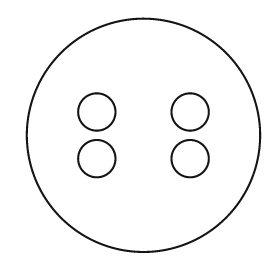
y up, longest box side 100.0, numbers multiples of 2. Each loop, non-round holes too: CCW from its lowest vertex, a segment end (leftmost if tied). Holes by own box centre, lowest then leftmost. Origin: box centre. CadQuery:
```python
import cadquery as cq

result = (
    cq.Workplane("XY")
    .moveTo(0.0, 0.0)
    .circle(50.0)
    .moveTo(-20.0, -10.0)
    .circle(8.0)
    .moveTo(20.0, -10.0)
    .circle(8.0)
    .moveTo(-20.0, 10.0)
    .circle(8.0)
    .moveTo(20.0, 10.0)
    .circle(8.0)
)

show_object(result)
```